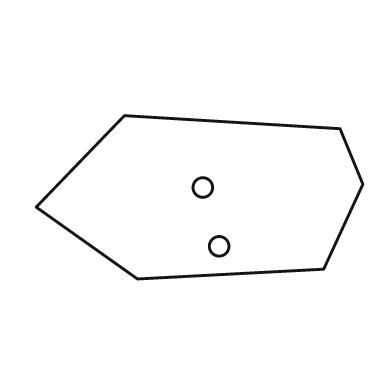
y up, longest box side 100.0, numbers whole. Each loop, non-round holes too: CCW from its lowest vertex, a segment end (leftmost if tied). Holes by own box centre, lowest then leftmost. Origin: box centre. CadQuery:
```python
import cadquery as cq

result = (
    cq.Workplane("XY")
    .moveTo(-19.0, -25.0)
    .lineTo(38.0, -22.0)
    .lineTo(50.0, 4.0)
    .lineTo(43.0, 21.0)
    .lineTo(-23.0, 25.0)
    .lineTo(-50.0, -3.0)
    .close()
    .moveTo(6.0, -15.0)
    .circle(3.0)
    .moveTo(1.0, 3.0)
    .circle(3.0)
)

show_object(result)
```